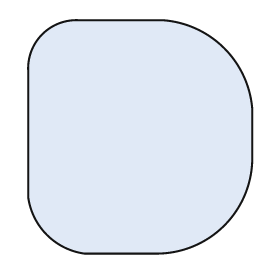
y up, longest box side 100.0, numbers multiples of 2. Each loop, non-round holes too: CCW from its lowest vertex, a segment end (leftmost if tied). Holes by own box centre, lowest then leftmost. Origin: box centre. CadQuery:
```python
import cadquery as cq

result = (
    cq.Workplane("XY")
    .moveTo(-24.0, -50.0)
    .lineTo(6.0, -50.0)
    .threePointArc((36.0, -38.0), (48.0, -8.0))
    .lineTo(48.0, 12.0)
    .threePointArc((36.0, 38.0), (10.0, 50.0))
    .lineTo(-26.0, 50.0)
    .threePointArc((-42.0, 44.0), (-48.0, 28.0))
    .lineTo(-48.0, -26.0)
    .threePointArc((-40.0, -42.0), (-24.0, -50.0))
    .close()
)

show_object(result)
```